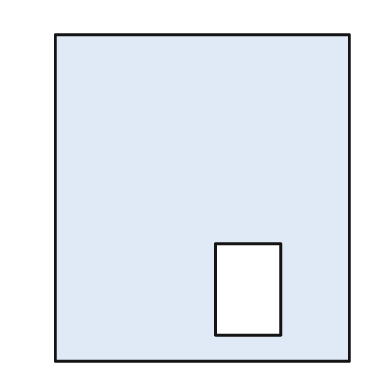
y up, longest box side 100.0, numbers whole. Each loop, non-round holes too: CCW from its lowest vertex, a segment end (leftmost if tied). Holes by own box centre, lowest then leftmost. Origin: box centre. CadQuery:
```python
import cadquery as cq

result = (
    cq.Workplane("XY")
    .moveTo(-45.0, -50.0)
    .lineTo(45.0, -50.0)
    .lineTo(45.0, 50.0)
    .lineTo(-45.0, 50.0)
    .close()
    .moveTo(4.0, -42.0)
    .lineTo(24.0, -42.0)
    .lineTo(24.0, -14.0)
    .lineTo(4.0, -14.0)
    .close()
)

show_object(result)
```